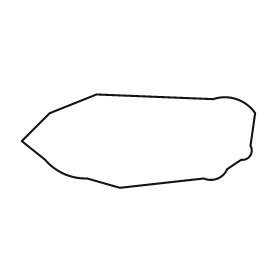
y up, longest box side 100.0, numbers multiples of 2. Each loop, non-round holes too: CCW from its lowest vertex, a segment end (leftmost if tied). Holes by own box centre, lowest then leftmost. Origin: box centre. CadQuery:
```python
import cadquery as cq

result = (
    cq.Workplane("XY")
    .moveTo(-8.0, -20.0)
    .lineTo(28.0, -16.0)
    .threePointArc((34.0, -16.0), (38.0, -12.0))
    .lineTo(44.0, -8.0)
    .threePointArc((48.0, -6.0), (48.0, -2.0))
    .lineTo(50.0, 12.0)
    .threePointArc((42.0, 18.0), (32.0, 18.0))
    .lineTo(-18.0, 20.0)
    .lineTo(-38.0, 12.0)
    .lineTo(-50.0, 0.0)
    .lineTo(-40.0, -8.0)
    .threePointArc((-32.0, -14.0), (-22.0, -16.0))
    .close()
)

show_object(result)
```